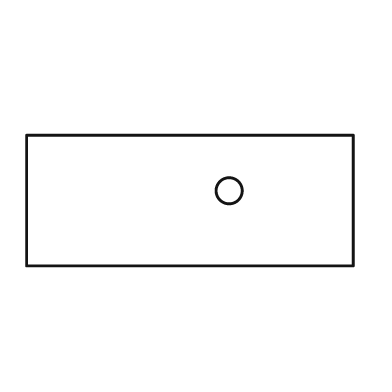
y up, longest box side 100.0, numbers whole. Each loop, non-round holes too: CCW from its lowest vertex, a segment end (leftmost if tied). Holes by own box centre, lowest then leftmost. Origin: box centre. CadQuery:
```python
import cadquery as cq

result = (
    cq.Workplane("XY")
    .moveTo(-50.0, -20.0)
    .lineTo(50.0, -20.0)
    .lineTo(50.0, 20.0)
    .lineTo(-50.0, 20.0)
    .close()
    .moveTo(12.0, 3.0)
    .circle(4.0)
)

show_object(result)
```